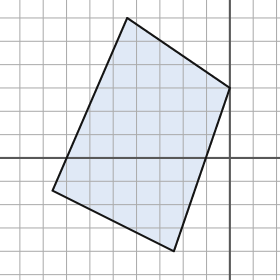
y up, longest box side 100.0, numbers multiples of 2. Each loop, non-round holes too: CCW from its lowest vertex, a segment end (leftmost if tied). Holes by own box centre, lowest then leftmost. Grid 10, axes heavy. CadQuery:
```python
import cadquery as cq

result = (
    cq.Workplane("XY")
    .moveTo(-24.0, -40.0)
    .lineTo(0.0, 30.0)
    .lineTo(-44.0, 60.0)
    .lineTo(-76.0, -14.0)
    .close()
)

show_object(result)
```